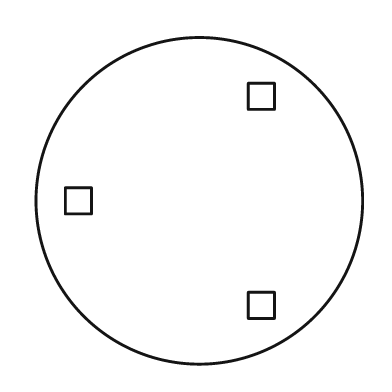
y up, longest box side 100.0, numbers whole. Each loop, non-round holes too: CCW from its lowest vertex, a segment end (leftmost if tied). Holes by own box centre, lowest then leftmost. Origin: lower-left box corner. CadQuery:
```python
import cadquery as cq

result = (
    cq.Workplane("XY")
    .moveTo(50.0, 50.0)
    .circle(50.0)
    .moveTo(65.0, 14.0)
    .lineTo(73.0, 14.0)
    .lineTo(73.0, 22.0)
    .lineTo(65.0, 22.0)
    .close()
    .moveTo(9.0, 46.0)
    .lineTo(17.0, 46.0)
    .lineTo(17.0, 54.0)
    .lineTo(9.0, 54.0)
    .close()
    .moveTo(65.0, 78.0)
    .lineTo(73.0, 78.0)
    .lineTo(73.0, 86.0)
    .lineTo(65.0, 86.0)
    .close()
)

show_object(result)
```